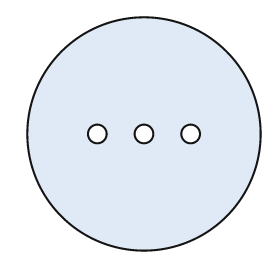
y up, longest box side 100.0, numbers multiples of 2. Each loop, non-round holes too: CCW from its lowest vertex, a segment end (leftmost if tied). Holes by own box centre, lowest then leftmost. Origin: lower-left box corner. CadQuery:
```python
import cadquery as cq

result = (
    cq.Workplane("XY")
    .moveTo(50.0, 50.0)
    .circle(50.0)
    .moveTo(30.0, 50.0)
    .circle(4.0)
    .moveTo(50.0, 50.0)
    .circle(4.0)
    .moveTo(70.0, 50.0)
    .circle(4.0)
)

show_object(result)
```